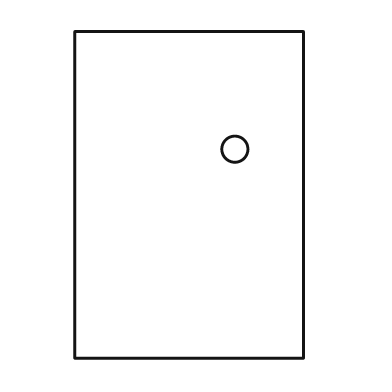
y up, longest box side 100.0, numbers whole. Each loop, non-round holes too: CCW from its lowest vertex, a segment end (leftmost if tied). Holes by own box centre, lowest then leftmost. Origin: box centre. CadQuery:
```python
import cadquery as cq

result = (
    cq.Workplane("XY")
    .moveTo(-35.0, -50.0)
    .lineTo(35.0, -50.0)
    .lineTo(35.0, 50.0)
    .lineTo(-35.0, 50.0)
    .close()
    .moveTo(14.0, 14.0)
    .circle(4.0)
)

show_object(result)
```